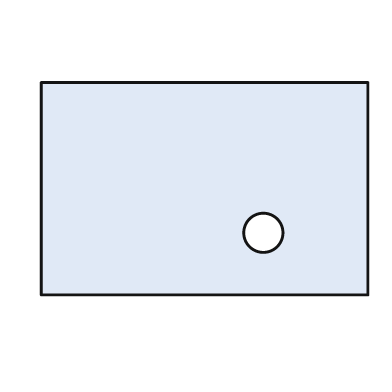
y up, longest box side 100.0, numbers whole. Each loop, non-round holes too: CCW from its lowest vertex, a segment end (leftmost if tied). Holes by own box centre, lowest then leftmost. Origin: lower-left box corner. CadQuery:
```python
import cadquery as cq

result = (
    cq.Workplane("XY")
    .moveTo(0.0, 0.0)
    .lineTo(100.0, 0.0)
    .lineTo(100.0, 65.0)
    .lineTo(0.0, 65.0)
    .close()
    .moveTo(68.0, 19.0)
    .circle(6.0)
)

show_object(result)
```